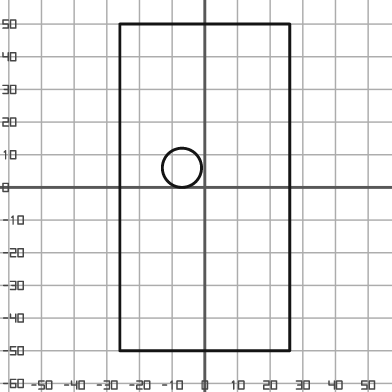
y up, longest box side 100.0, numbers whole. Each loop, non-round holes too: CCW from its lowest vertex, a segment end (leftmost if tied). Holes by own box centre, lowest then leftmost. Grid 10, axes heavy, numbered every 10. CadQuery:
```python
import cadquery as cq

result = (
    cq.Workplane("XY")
    .moveTo(-26.0, -50.0)
    .lineTo(26.0, -50.0)
    .lineTo(26.0, 50.0)
    .lineTo(-26.0, 50.0)
    .close()
    .moveTo(-7.0, 6.0)
    .circle(6.0)
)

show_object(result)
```